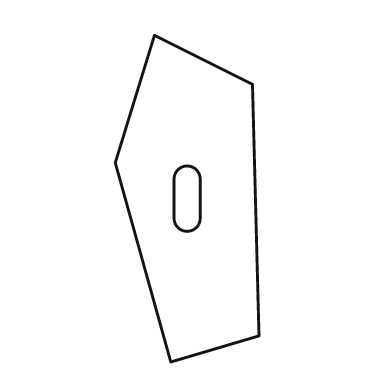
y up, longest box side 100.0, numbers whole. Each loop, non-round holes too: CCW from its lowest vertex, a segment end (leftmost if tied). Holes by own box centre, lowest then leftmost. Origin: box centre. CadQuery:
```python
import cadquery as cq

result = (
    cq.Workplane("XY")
    .moveTo(-5.0, -50.0)
    .lineTo(22.0, -42.0)
    .lineTo(20.0, 35.0)
    .lineTo(-10.0, 50.0)
    .lineTo(-22.0, 11.0)
    .close()
    .moveTo(-4.0, -6.0)
    .threePointArc((0.0, -10.0), (4.0, -6.0))
    .lineTo(4.0, 6.0)
    .threePointArc((0.0, 10.0), (-4.0, 6.0))
    .close()
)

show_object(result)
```